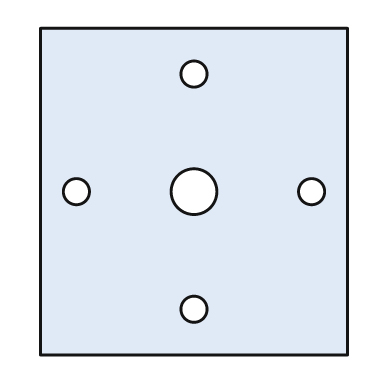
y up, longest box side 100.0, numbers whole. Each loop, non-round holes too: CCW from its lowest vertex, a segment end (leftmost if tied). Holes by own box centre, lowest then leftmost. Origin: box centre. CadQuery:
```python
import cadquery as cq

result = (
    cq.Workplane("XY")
    .moveTo(-47.0, -50.0)
    .lineTo(47.0, -50.0)
    .lineTo(47.0, 50.0)
    .lineTo(-47.0, 50.0)
    .close()
    .moveTo(0.0, -36.0)
    .circle(4.0)
    .moveTo(-36.0, 0.0)
    .circle(4.0)
    .moveTo(0.0, 0.0)
    .circle(7.0)
    .moveTo(36.0, 0.0)
    .circle(4.0)
    .moveTo(0.0, 36.0)
    .circle(4.0)
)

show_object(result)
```